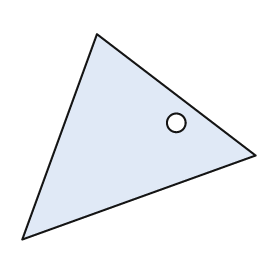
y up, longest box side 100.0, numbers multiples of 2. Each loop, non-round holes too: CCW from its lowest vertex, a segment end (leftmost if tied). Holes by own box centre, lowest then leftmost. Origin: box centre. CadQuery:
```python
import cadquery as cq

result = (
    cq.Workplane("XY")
    .moveTo(-50.0, -44.0)
    .lineTo(50.0, -8.0)
    .lineTo(-18.0, 44.0)
    .close()
    .moveTo(16.0, 6.0)
    .circle(4.0)
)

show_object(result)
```